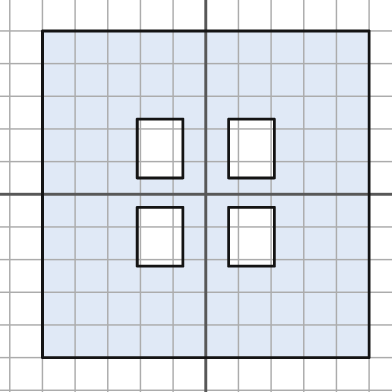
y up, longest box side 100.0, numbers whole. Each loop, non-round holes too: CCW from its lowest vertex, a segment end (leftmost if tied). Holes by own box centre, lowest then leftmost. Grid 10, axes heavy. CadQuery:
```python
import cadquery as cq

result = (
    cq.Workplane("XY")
    .moveTo(-50.0, -50.0)
    .lineTo(50.0, -50.0)
    .lineTo(50.0, 50.0)
    .lineTo(-50.0, 50.0)
    .close()
    .moveTo(-21.0, -22.0)
    .lineTo(-7.0, -22.0)
    .lineTo(-7.0, -4.0)
    .lineTo(-21.0, -4.0)
    .close()
    .moveTo(7.0, -22.0)
    .lineTo(21.0, -22.0)
    .lineTo(21.0, -4.0)
    .lineTo(7.0, -4.0)
    .close()
    .moveTo(-21.0, 5.0)
    .lineTo(-7.0, 5.0)
    .lineTo(-7.0, 23.0)
    .lineTo(-21.0, 23.0)
    .close()
    .moveTo(7.0, 5.0)
    .lineTo(21.0, 5.0)
    .lineTo(21.0, 23.0)
    .lineTo(7.0, 23.0)
    .close()
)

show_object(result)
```